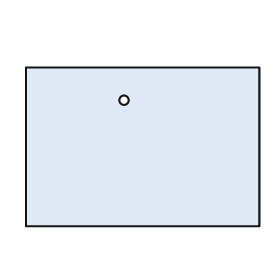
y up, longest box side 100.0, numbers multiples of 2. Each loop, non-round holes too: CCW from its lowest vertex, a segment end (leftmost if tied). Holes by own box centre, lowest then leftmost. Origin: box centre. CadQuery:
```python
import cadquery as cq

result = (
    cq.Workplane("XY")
    .moveTo(-50.0, -34.0)
    .lineTo(50.0, -34.0)
    .lineTo(50.0, 34.0)
    .lineTo(-50.0, 34.0)
    .close()
    .moveTo(-8.0, 20.0)
    .circle(2.0)
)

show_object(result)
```